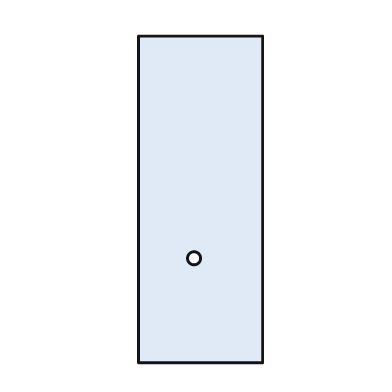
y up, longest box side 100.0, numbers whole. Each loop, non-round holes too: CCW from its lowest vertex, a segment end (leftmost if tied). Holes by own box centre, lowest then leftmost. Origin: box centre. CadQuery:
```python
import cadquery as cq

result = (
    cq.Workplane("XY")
    .moveTo(-19.0, -50.0)
    .lineTo(19.0, -50.0)
    .lineTo(19.0, 50.0)
    .lineTo(-19.0, 50.0)
    .close()
    .moveTo(-2.0, -18.0)
    .circle(2.0)
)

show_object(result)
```